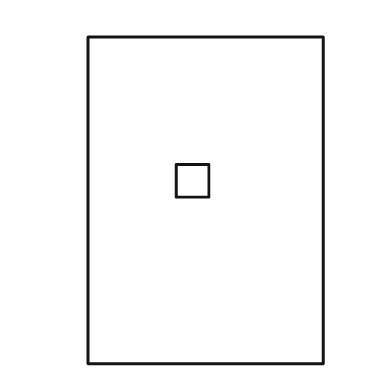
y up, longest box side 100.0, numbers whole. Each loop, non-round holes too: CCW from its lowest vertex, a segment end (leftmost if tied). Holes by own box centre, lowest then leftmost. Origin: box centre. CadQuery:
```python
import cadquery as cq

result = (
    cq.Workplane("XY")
    .moveTo(-36.0, -50.0)
    .lineTo(36.0, -50.0)
    .lineTo(36.0, 50.0)
    .lineTo(-36.0, 50.0)
    .close()
    .moveTo(-9.0, 1.0)
    .lineTo(1.0, 1.0)
    .lineTo(1.0, 11.0)
    .lineTo(-9.0, 11.0)
    .close()
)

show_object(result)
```